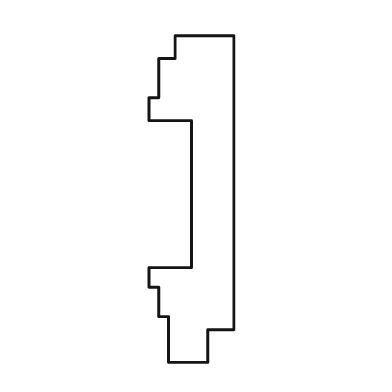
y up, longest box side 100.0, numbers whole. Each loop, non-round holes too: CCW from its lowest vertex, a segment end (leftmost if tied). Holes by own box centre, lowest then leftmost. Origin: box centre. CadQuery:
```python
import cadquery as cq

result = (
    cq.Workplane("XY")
    .moveTo(-7.0, -50.0)
    .lineTo(5.0, -50.0)
    .lineTo(5.0, -40.0)
    .lineTo(13.0, -40.0)
    .lineTo(13.0, 50.0)
    .lineTo(-5.0, 50.0)
    .lineTo(-5.0, 43.0)
    .lineTo(-10.0, 43.0)
    .lineTo(-10.0, 31.0)
    .lineTo(-13.0, 31.0)
    .lineTo(-13.0, 24.0)
    .lineTo(0.0, 24.0)
    .lineTo(0.0, -21.0)
    .lineTo(-13.0, -21.0)
    .lineTo(-13.0, -27.0)
    .lineTo(-10.0, -27.0)
    .lineTo(-10.0, -36.0)
    .lineTo(-7.0, -36.0)
    .close()
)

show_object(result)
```